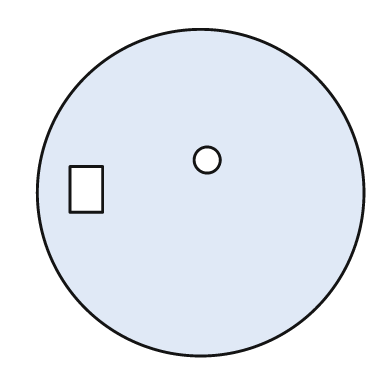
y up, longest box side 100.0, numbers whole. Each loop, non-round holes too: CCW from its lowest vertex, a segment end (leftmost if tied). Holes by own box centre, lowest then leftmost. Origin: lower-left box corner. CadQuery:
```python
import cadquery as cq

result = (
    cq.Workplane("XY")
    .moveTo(50.0, 50.0)
    .circle(50.0)
    .moveTo(10.0, 44.0)
    .lineTo(20.0, 44.0)
    .lineTo(20.0, 58.0)
    .lineTo(10.0, 58.0)
    .close()
    .moveTo(52.0, 60.0)
    .circle(4.0)
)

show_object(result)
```